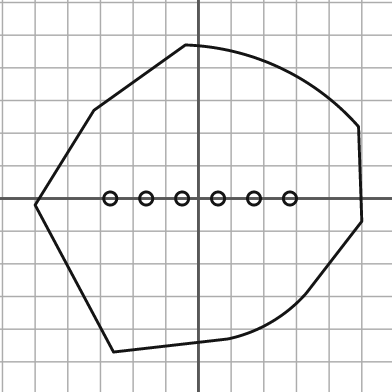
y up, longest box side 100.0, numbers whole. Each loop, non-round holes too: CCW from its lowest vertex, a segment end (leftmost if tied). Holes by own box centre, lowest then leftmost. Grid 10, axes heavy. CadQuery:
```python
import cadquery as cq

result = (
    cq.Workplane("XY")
    .moveTo(-26.0, -47.0)
    .lineTo(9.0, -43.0)
    .threePointArc((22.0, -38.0), (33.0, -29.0))
    .lineTo(50.0, -7.0)
    .lineTo(49.0, 22.0)
    .threePointArc((25.0, 40.0), (-4.0, 47.0))
    .lineTo(-32.0, 27.0)
    .lineTo(-50.0, -2.0)
    .close()
    .moveTo(-27.0, 0.0)
    .circle(2.0)
    .moveTo(-16.0, 0.0)
    .circle(2.0)
    .moveTo(-5.0, 0.0)
    .circle(2.0)
    .moveTo(6.0, 0.0)
    .circle(2.0)
    .moveTo(17.0, 0.0)
    .circle(2.0)
    .moveTo(28.0, 0.0)
    .circle(2.0)
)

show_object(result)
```